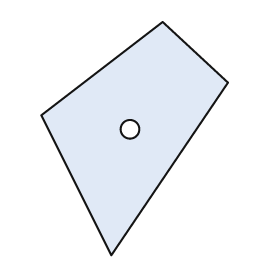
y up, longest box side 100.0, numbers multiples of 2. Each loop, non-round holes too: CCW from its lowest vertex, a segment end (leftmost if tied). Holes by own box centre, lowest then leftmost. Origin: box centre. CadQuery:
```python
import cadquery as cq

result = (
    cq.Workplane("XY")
    .moveTo(-10.0, -50.0)
    .lineTo(40.0, 24.0)
    .lineTo(12.0, 50.0)
    .lineTo(-40.0, 10.0)
    .close()
    .moveTo(-2.0, 4.0)
    .circle(4.0)
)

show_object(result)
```